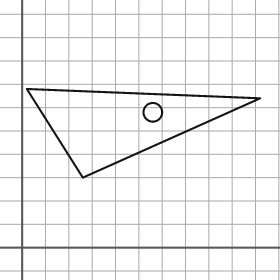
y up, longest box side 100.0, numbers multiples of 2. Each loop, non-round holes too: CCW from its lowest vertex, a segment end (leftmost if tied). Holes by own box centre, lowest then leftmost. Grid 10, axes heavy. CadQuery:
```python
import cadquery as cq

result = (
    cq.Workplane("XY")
    .moveTo(26.0, 30.0)
    .lineTo(102.0, 64.0)
    .lineTo(2.0, 68.0)
    .close()
    .moveTo(56.0, 58.0)
    .circle(4.0)
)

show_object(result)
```